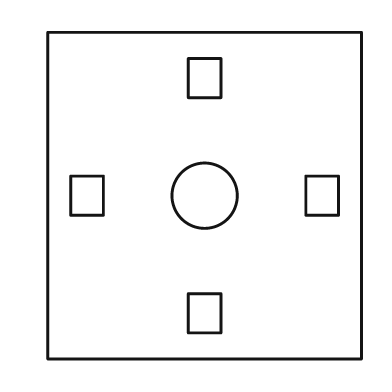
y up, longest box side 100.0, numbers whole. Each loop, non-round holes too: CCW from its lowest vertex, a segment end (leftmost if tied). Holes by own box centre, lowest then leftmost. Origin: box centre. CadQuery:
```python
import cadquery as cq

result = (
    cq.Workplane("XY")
    .moveTo(-48.0, -50.0)
    .lineTo(48.0, -50.0)
    .lineTo(48.0, 50.0)
    .lineTo(-48.0, 50.0)
    .close()
    .moveTo(-5.0, -42.0)
    .lineTo(5.0, -42.0)
    .lineTo(5.0, -30.0)
    .lineTo(-5.0, -30.0)
    .close()
    .moveTo(-41.0, -6.0)
    .lineTo(-31.0, -6.0)
    .lineTo(-31.0, 6.0)
    .lineTo(-41.0, 6.0)
    .close()
    .moveTo(0.0, 0.0)
    .circle(10.0)
    .moveTo(31.0, -6.0)
    .lineTo(41.0, -6.0)
    .lineTo(41.0, 6.0)
    .lineTo(31.0, 6.0)
    .close()
    .moveTo(-5.0, 30.0)
    .lineTo(5.0, 30.0)
    .lineTo(5.0, 42.0)
    .lineTo(-5.0, 42.0)
    .close()
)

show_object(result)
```